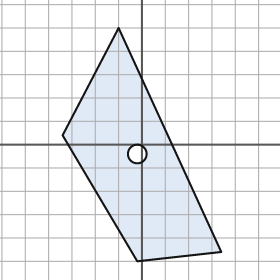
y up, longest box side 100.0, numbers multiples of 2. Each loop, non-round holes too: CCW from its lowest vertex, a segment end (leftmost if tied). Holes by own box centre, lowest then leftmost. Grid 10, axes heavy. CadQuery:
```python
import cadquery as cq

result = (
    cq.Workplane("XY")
    .moveTo(-2.0, -50.0)
    .lineTo(34.0, -46.0)
    .lineTo(-10.0, 50.0)
    .lineTo(-34.0, 4.0)
    .close()
    .moveTo(-2.0, -4.0)
    .circle(4.0)
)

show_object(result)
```